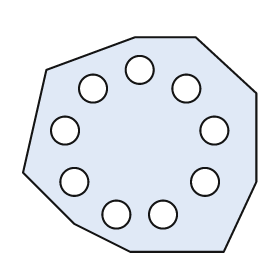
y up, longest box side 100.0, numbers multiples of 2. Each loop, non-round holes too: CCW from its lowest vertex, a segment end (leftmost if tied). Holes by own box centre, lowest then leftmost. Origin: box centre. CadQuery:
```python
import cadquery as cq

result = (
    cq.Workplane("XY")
    .moveTo(-4.0, -46.0)
    .lineTo(36.0, -46.0)
    .lineTo(50.0, -16.0)
    .lineTo(50.0, 22.0)
    .lineTo(24.0, 46.0)
    .lineTo(-2.0, 46.0)
    .lineTo(-40.0, 32.0)
    .lineTo(-50.0, -12.0)
    .lineTo(-28.0, -34.0)
    .close()
    .moveTo(-10.0, -30.0)
    .circle(6.0)
    .moveTo(10.0, -30.0)
    .circle(6.0)
    .moveTo(-28.0, -16.0)
    .circle(6.0)
    .moveTo(28.0, -16.0)
    .circle(6.0)
    .moveTo(-32.0, 6.0)
    .circle(6.0)
    .moveTo(32.0, 6.0)
    .circle(6.0)
    .moveTo(-20.0, 24.0)
    .circle(6.0)
    .moveTo(20.0, 24.0)
    .circle(6.0)
    .moveTo(0.0, 32.0)
    .circle(6.0)
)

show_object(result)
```